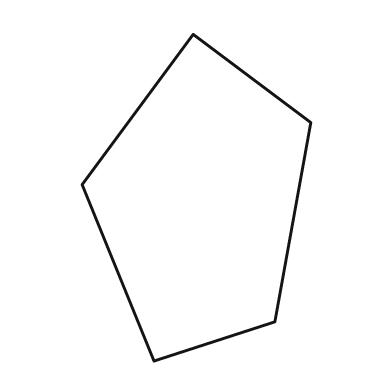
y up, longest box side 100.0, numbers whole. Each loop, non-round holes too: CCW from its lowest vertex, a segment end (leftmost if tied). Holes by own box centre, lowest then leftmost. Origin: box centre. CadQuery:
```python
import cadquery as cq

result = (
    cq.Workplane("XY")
    .moveTo(-13.0, -50.0)
    .lineTo(24.0, -38.0)
    .lineTo(35.0, 23.0)
    .lineTo(-1.0, 50.0)
    .lineTo(-35.0, 4.0)
    .close()
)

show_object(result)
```